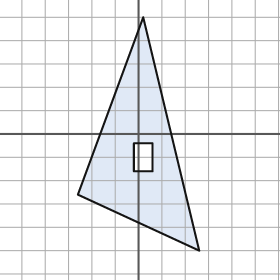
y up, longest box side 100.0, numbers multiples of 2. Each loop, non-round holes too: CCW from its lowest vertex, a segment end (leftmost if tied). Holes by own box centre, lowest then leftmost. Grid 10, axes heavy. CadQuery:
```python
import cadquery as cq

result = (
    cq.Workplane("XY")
    .moveTo(26.0, -50.0)
    .lineTo(2.0, 50.0)
    .lineTo(-26.0, -26.0)
    .close()
    .moveTo(-2.0, -16.0)
    .lineTo(6.0, -16.0)
    .lineTo(6.0, -4.0)
    .lineTo(-2.0, -4.0)
    .close()
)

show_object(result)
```